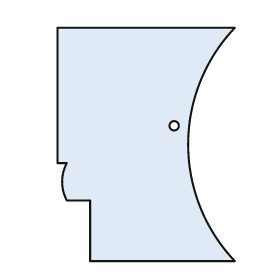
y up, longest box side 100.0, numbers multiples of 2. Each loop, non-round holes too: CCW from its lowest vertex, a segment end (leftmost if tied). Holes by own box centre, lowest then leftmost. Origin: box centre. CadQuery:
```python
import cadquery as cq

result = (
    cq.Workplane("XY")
    .moveTo(-24.0, -50.0)
    .lineTo(38.0, -50.0)
    .threePointArc((18.0, 0.0), (38.0, 50.0))
    .lineTo(-38.0, 50.0)
    .lineTo(-38.0, -8.0)
    .lineTo(-34.0, -8.0)
    .threePointArc((-36.0, -16.0), (-34.0, -24.0))
    .lineTo(-24.0, -24.0)
    .close()
    .moveTo(12.0, 8.0)
    .circle(2.0)
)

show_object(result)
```